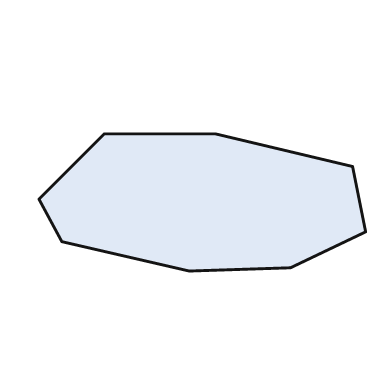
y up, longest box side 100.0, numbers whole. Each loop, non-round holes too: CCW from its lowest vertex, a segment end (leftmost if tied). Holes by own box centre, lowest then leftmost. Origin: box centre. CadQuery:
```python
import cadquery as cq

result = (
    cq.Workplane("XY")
    .moveTo(-4.0, -21.0)
    .lineTo(27.0, -20.0)
    .lineTo(50.0, -9.0)
    .lineTo(46.0, 11.0)
    .lineTo(4.0, 21.0)
    .lineTo(-30.0, 21.0)
    .lineTo(-50.0, 1.0)
    .lineTo(-43.0, -12.0)
    .close()
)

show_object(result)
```